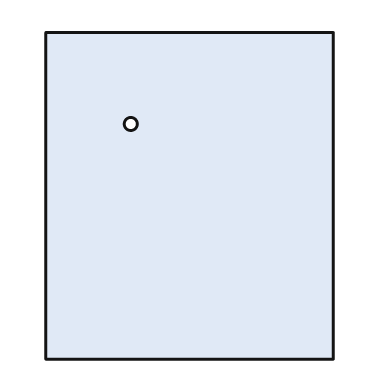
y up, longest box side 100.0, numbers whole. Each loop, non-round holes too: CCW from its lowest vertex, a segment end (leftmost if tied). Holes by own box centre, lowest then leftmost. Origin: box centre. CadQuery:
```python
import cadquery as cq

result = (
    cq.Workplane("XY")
    .moveTo(-44.0, -50.0)
    .lineTo(44.0, -50.0)
    .lineTo(44.0, 50.0)
    .lineTo(-44.0, 50.0)
    .close()
    .moveTo(-18.0, 22.0)
    .circle(2.0)
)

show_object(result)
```